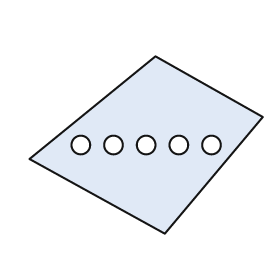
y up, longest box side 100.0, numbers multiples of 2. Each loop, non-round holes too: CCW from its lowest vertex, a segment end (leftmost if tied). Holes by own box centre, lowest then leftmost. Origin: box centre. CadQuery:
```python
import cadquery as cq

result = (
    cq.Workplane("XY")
    .moveTo(8.0, -38.0)
    .lineTo(50.0, 12.0)
    .lineTo(4.0, 38.0)
    .lineTo(-50.0, -6.0)
    .close()
    .moveTo(-28.0, 0.0)
    .circle(4.0)
    .moveTo(-14.0, 0.0)
    .circle(4.0)
    .moveTo(0.0, 0.0)
    .circle(4.0)
    .moveTo(14.0, 0.0)
    .circle(4.0)
    .moveTo(28.0, 0.0)
    .circle(4.0)
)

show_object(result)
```